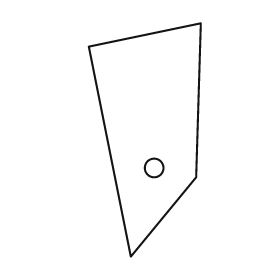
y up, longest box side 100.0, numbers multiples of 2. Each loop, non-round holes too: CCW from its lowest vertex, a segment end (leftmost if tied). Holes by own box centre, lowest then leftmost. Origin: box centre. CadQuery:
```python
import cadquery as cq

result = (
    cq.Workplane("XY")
    .moveTo(-6.0, -50.0)
    .lineTo(22.0, -16.0)
    .lineTo(24.0, 50.0)
    .lineTo(-24.0, 40.0)
    .close()
    .moveTo(4.0, -12.0)
    .circle(4.0)
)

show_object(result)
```